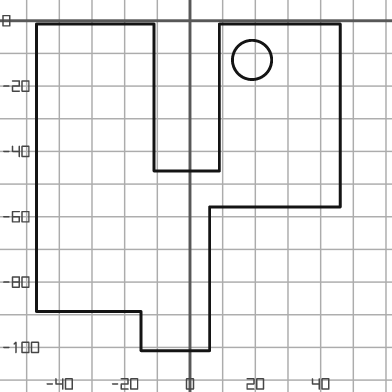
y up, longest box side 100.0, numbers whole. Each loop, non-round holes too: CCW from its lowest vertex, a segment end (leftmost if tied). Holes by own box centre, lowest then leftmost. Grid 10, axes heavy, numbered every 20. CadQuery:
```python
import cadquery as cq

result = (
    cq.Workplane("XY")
    .moveTo(-15.0, -101.0)
    .lineTo(6.0, -101.0)
    .lineTo(6.0, -57.0)
    .lineTo(46.0, -57.0)
    .lineTo(46.0, -1.0)
    .lineTo(9.0, -1.0)
    .lineTo(9.0, -46.0)
    .lineTo(-11.0, -46.0)
    .lineTo(-11.0, -1.0)
    .lineTo(-47.0, -1.0)
    .lineTo(-47.0, -89.0)
    .lineTo(-15.0, -89.0)
    .close()
    .moveTo(19.0, -12.0)
    .circle(6.0)
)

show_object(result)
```